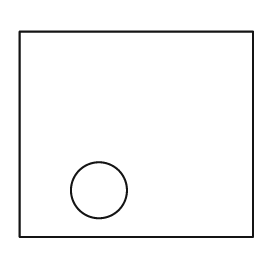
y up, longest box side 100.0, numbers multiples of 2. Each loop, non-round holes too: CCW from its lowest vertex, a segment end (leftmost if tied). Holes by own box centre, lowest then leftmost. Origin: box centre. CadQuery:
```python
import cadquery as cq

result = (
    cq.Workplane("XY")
    .moveTo(-50.0, -44.0)
    .lineTo(50.0, -44.0)
    .lineTo(50.0, 44.0)
    .lineTo(-50.0, 44.0)
    .close()
    .moveTo(-16.0, -24.0)
    .circle(12.0)
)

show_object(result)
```